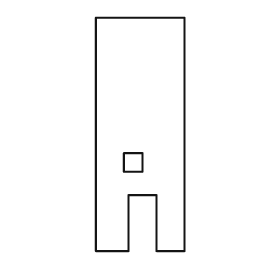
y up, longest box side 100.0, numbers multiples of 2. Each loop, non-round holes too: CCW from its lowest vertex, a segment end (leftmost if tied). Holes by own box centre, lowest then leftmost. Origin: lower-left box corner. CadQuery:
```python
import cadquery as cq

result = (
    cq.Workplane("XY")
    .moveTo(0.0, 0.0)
    .lineTo(14.0, 0.0)
    .lineTo(14.0, 24.0)
    .lineTo(26.0, 24.0)
    .lineTo(26.0, 0.0)
    .lineTo(38.0, 0.0)
    .lineTo(38.0, 100.0)
    .lineTo(0.0, 100.0)
    .close()
    .moveTo(12.0, 34.0)
    .lineTo(20.0, 34.0)
    .lineTo(20.0, 42.0)
    .lineTo(12.0, 42.0)
    .close()
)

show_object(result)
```